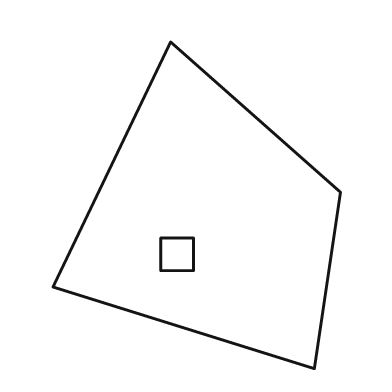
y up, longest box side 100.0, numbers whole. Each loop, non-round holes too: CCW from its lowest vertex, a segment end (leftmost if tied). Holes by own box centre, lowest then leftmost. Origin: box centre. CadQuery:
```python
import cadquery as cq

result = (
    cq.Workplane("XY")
    .moveTo(36.0, -50.0)
    .lineTo(44.0, 4.0)
    .lineTo(-8.0, 50.0)
    .lineTo(-44.0, -25.0)
    .close()
    .moveTo(-11.0, -20.0)
    .lineTo(-1.0, -20.0)
    .lineTo(-1.0, -10.0)
    .lineTo(-11.0, -10.0)
    .close()
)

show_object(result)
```